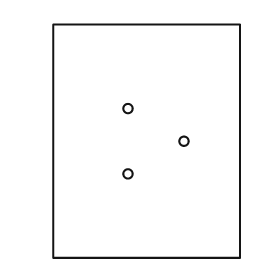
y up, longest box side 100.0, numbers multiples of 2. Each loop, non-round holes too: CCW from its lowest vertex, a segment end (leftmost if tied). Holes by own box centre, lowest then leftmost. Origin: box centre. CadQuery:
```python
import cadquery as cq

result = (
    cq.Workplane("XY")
    .moveTo(-40.0, -50.0)
    .lineTo(40.0, -50.0)
    .lineTo(40.0, 50.0)
    .lineTo(-40.0, 50.0)
    .close()
    .moveTo(-8.0, -14.0)
    .circle(2.0)
    .moveTo(16.0, 0.0)
    .circle(2.0)
    .moveTo(-8.0, 14.0)
    .circle(2.0)
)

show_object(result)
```